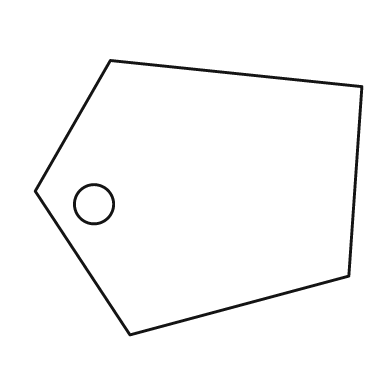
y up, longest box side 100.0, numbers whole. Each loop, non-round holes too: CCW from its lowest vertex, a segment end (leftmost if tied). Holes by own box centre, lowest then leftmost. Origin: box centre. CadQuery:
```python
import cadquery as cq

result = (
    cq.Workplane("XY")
    .moveTo(-21.0, -42.0)
    .lineTo(46.0, -24.0)
    .lineTo(50.0, 34.0)
    .lineTo(-27.0, 42.0)
    .lineTo(-50.0, 2.0)
    .close()
    .moveTo(-32.0, -2.0)
    .circle(6.0)
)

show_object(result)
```